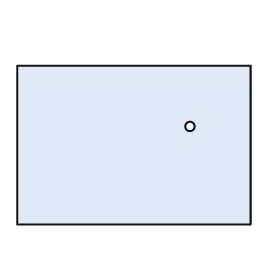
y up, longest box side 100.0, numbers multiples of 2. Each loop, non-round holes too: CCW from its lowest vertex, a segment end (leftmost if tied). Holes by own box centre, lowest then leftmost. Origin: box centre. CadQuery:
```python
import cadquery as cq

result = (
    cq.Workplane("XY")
    .moveTo(-50.0, -34.0)
    .lineTo(50.0, -34.0)
    .lineTo(50.0, 34.0)
    .lineTo(-50.0, 34.0)
    .close()
    .moveTo(24.0, 8.0)
    .circle(2.0)
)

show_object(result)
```